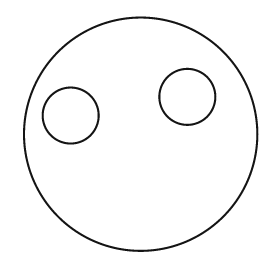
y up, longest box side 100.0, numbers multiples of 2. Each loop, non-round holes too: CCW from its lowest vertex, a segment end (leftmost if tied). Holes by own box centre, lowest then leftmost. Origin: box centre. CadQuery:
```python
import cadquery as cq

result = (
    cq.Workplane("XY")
    .moveTo(0.0, 0.0)
    .circle(50.0)
    .moveTo(-30.0, 8.0)
    .circle(12.0)
    .moveTo(20.0, 16.0)
    .circle(12.0)
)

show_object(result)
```